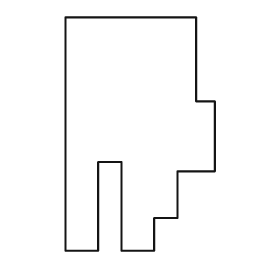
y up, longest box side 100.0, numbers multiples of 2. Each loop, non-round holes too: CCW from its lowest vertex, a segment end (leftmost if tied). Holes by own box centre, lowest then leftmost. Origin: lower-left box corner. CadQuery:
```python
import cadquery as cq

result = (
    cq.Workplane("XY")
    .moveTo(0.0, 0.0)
    .lineTo(14.0, 0.0)
    .lineTo(14.0, 38.0)
    .lineTo(24.0, 38.0)
    .lineTo(24.0, 0.0)
    .lineTo(38.0, 0.0)
    .lineTo(38.0, 14.0)
    .lineTo(48.0, 14.0)
    .lineTo(48.0, 34.0)
    .lineTo(64.0, 34.0)
    .lineTo(64.0, 64.0)
    .lineTo(56.0, 64.0)
    .lineTo(56.0, 100.0)
    .lineTo(0.0, 100.0)
    .close()
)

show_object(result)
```